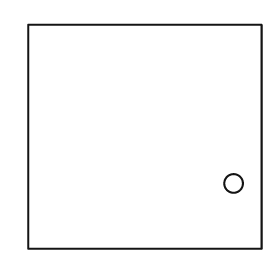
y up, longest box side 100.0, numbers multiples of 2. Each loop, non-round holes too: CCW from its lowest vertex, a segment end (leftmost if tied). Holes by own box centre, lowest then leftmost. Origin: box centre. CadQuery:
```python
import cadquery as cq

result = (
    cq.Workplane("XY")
    .moveTo(-50.0, -48.0)
    .lineTo(50.0, -48.0)
    .lineTo(50.0, 48.0)
    .lineTo(-50.0, 48.0)
    .close()
    .moveTo(38.0, -20.0)
    .circle(4.0)
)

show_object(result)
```